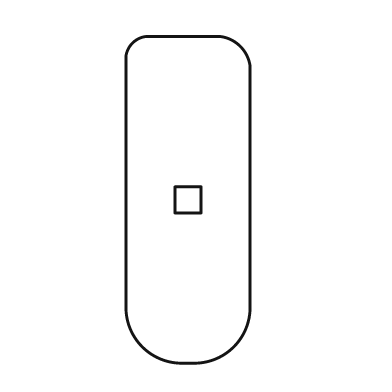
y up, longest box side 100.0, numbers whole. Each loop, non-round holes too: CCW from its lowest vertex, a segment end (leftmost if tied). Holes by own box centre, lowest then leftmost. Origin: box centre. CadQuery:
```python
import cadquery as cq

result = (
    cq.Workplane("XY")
    .moveTo(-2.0, -50.0)
    .lineTo(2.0, -50.0)
    .threePointArc((14.0, -45.0), (19.0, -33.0))
    .lineTo(19.0, 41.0)
    .threePointArc((16.0, 47.0), (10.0, 50.0))
    .lineTo(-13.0, 50.0)
    .threePointArc((-17.0, 48.0), (-19.0, 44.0))
    .lineTo(-19.0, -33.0)
    .threePointArc((-14.0, -45.0), (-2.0, -50.0))
    .close()
    .moveTo(-4.0, -4.0)
    .lineTo(4.0, -4.0)
    .lineTo(4.0, 4.0)
    .lineTo(-4.0, 4.0)
    .close()
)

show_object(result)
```